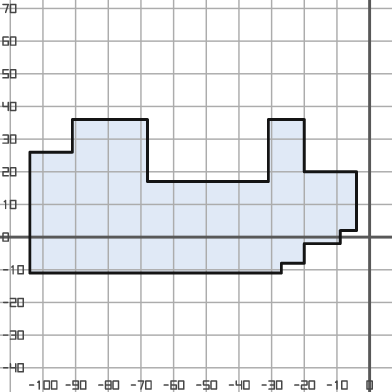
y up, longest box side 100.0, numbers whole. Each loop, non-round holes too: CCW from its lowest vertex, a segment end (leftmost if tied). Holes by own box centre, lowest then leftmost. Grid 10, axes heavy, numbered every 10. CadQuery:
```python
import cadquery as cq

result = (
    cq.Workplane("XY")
    .moveTo(-104.0, -11.0)
    .lineTo(-27.0, -11.0)
    .lineTo(-27.0, -8.0)
    .lineTo(-20.0, -8.0)
    .lineTo(-20.0, -2.0)
    .lineTo(-9.0, -2.0)
    .lineTo(-9.0, 2.0)
    .lineTo(-4.0, 2.0)
    .lineTo(-4.0, 20.0)
    .lineTo(-20.0, 20.0)
    .lineTo(-20.0, 36.0)
    .lineTo(-31.0, 36.0)
    .lineTo(-31.0, 17.0)
    .lineTo(-68.0, 17.0)
    .lineTo(-68.0, 36.0)
    .lineTo(-91.0, 36.0)
    .lineTo(-91.0, 26.0)
    .lineTo(-104.0, 26.0)
    .close()
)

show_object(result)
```